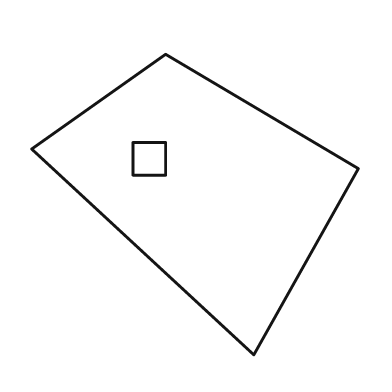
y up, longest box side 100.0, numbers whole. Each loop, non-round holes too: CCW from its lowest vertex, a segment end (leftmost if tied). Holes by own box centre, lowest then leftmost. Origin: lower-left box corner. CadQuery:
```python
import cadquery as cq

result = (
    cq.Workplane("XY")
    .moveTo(68.0, 0.0)
    .lineTo(100.0, 57.0)
    .lineTo(41.0, 92.0)
    .lineTo(0.0, 63.0)
    .close()
    .moveTo(31.0, 55.0)
    .lineTo(41.0, 55.0)
    .lineTo(41.0, 65.0)
    .lineTo(31.0, 65.0)
    .close()
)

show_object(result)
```